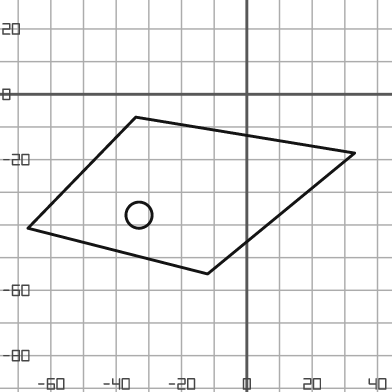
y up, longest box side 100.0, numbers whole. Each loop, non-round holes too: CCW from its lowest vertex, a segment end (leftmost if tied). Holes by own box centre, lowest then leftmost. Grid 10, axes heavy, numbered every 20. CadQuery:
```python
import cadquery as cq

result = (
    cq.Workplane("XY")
    .moveTo(-12.0, -55.0)
    .lineTo(33.0, -18.0)
    .lineTo(-34.0, -7.0)
    .lineTo(-67.0, -41.0)
    .close()
    .moveTo(-33.0, -37.0)
    .circle(4.0)
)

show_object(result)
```